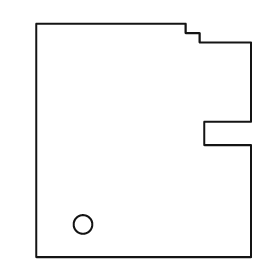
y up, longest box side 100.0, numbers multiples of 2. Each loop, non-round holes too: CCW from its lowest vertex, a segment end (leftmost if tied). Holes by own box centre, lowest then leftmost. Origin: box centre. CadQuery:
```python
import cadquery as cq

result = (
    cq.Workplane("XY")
    .moveTo(-46.0, -50.0)
    .lineTo(46.0, -50.0)
    .lineTo(46.0, -2.0)
    .lineTo(26.0, -2.0)
    .lineTo(26.0, 8.0)
    .lineTo(46.0, 8.0)
    .lineTo(46.0, 42.0)
    .lineTo(24.0, 42.0)
    .lineTo(24.0, 46.0)
    .lineTo(18.0, 46.0)
    .lineTo(18.0, 50.0)
    .lineTo(-46.0, 50.0)
    .close()
    .moveTo(-26.0, -36.0)
    .circle(4.0)
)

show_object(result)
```